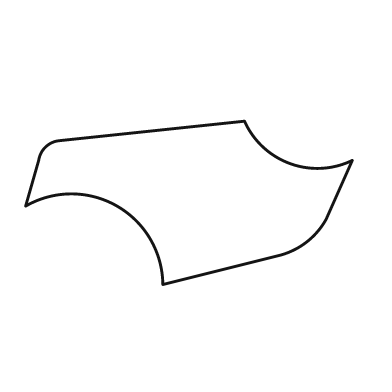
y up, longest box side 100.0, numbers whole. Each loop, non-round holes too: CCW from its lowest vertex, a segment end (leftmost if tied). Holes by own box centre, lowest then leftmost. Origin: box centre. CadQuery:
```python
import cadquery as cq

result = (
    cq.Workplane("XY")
    .moveTo(-8.0, -25.0)
    .lineTo(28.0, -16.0)
    .threePointArc((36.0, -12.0), (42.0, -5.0))
    .lineTo(50.0, 13.0)
    .threePointArc((31.0, 12.0), (17.0, 25.0))
    .lineTo(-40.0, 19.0)
    .threePointArc((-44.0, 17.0), (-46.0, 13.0))
    .lineTo(-50.0, -1.0)
    .threePointArc((-22.0, -1.0), (-8.0, -25.0))
    .close()
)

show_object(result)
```